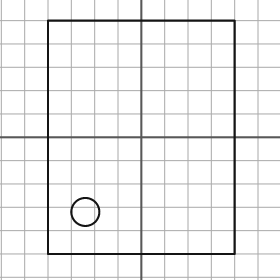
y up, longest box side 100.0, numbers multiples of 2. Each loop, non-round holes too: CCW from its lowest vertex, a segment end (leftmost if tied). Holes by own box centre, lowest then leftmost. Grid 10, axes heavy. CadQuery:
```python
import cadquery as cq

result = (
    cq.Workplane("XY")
    .moveTo(-40.0, -50.0)
    .lineTo(40.0, -50.0)
    .lineTo(40.0, 50.0)
    .lineTo(-40.0, 50.0)
    .close()
    .moveTo(-24.0, -32.0)
    .circle(6.0)
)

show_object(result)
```